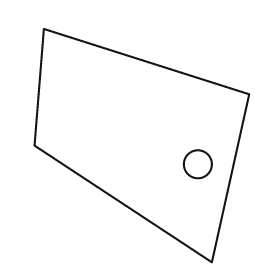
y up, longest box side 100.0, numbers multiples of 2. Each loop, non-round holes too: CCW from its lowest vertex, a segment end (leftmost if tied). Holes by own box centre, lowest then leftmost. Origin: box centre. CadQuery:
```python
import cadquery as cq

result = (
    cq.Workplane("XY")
    .moveTo(30.0, -50.0)
    .lineTo(46.0, 22.0)
    .lineTo(-42.0, 50.0)
    .lineTo(-46.0, 0.0)
    .close()
    .moveTo(24.0, -8.0)
    .circle(6.0)
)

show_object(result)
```